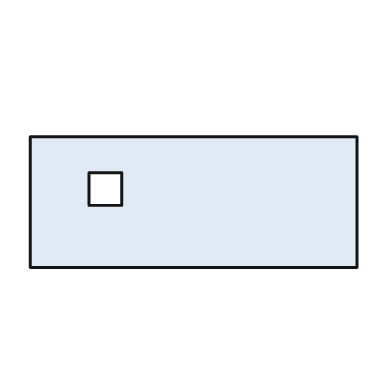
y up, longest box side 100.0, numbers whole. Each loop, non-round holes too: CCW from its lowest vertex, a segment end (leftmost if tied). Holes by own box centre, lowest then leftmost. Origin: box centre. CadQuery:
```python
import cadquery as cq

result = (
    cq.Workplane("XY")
    .moveTo(-50.0, -20.0)
    .lineTo(50.0, -20.0)
    .lineTo(50.0, 20.0)
    .lineTo(-50.0, 20.0)
    .close()
    .moveTo(-32.0, -1.0)
    .lineTo(-22.0, -1.0)
    .lineTo(-22.0, 9.0)
    .lineTo(-32.0, 9.0)
    .close()
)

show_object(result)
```